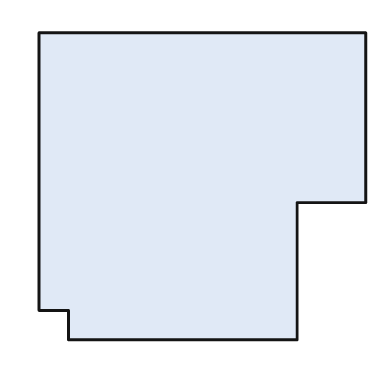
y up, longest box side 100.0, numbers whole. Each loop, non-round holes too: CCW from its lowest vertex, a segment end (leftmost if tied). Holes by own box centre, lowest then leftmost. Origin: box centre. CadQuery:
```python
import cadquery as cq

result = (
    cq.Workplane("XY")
    .moveTo(-41.0, -47.0)
    .lineTo(29.0, -47.0)
    .lineTo(29.0, -5.0)
    .lineTo(50.0, -5.0)
    .lineTo(50.0, 47.0)
    .lineTo(-50.0, 47.0)
    .lineTo(-50.0, -38.0)
    .lineTo(-41.0, -38.0)
    .close()
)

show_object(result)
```